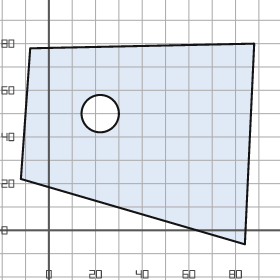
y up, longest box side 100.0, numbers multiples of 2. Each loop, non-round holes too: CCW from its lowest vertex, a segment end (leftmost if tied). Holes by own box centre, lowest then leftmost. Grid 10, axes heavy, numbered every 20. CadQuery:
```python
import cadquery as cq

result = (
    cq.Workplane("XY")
    .moveTo(84.0, -6.0)
    .lineTo(88.0, 80.0)
    .lineTo(-8.0, 78.0)
    .lineTo(-12.0, 22.0)
    .close()
    .moveTo(22.0, 50.0)
    .circle(8.0)
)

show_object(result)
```